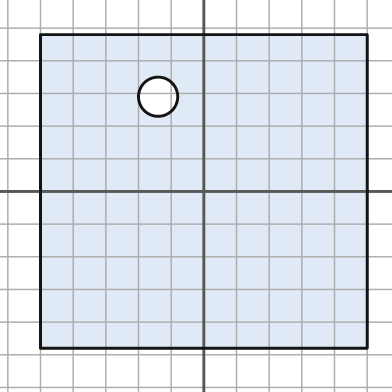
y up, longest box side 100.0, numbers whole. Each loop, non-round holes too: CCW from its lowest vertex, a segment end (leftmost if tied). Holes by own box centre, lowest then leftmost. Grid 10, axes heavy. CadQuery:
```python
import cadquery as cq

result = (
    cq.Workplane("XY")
    .moveTo(-50.0, -48.0)
    .lineTo(50.0, -48.0)
    .lineTo(50.0, 48.0)
    .lineTo(-50.0, 48.0)
    .close()
    .moveTo(-14.0, 29.0)
    .circle(6.0)
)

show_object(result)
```